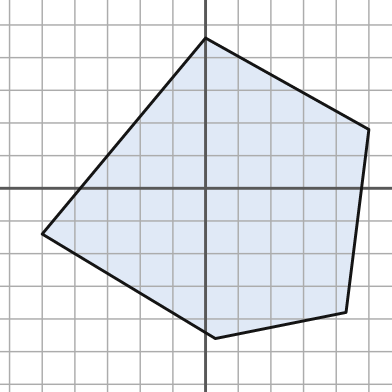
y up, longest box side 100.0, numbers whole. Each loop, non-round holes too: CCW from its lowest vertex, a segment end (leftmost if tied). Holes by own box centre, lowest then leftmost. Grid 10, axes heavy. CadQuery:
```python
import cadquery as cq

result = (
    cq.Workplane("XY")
    .moveTo(3.0, -46.0)
    .lineTo(43.0, -38.0)
    .lineTo(50.0, 18.0)
    .lineTo(0.0, 46.0)
    .lineTo(-50.0, -14.0)
    .close()
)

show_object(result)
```